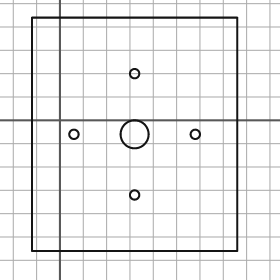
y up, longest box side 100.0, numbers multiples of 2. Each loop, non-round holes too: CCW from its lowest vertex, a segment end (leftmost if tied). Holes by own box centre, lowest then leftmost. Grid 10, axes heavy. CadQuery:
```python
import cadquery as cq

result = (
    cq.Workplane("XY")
    .moveTo(-12.0, -56.0)
    .lineTo(76.0, -56.0)
    .lineTo(76.0, 44.0)
    .lineTo(-12.0, 44.0)
    .close()
    .moveTo(32.0, -32.0)
    .circle(2.0)
    .moveTo(6.0, -6.0)
    .circle(2.0)
    .moveTo(32.0, -6.0)
    .circle(6.0)
    .moveTo(58.0, -6.0)
    .circle(2.0)
    .moveTo(32.0, 20.0)
    .circle(2.0)
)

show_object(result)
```